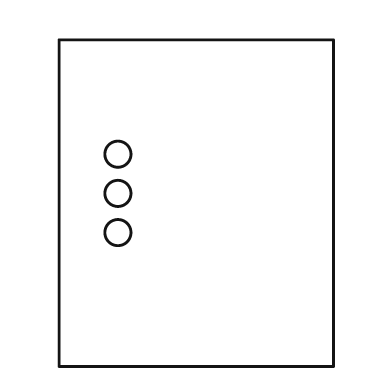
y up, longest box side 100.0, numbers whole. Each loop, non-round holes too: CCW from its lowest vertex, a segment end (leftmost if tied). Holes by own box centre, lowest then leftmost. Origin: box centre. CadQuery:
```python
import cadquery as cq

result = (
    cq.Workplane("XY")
    .moveTo(-42.0, -50.0)
    .lineTo(42.0, -50.0)
    .lineTo(42.0, 50.0)
    .lineTo(-42.0, 50.0)
    .close()
    .moveTo(-24.0, -9.0)
    .circle(4.0)
    .moveTo(-24.0, 3.0)
    .circle(4.0)
    .moveTo(-24.0, 15.0)
    .circle(4.0)
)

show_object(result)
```